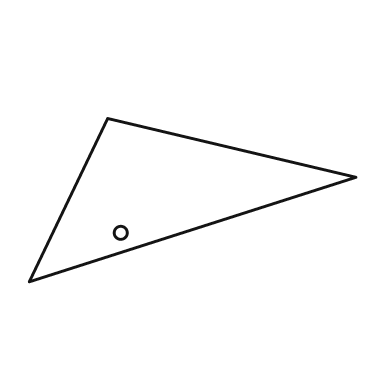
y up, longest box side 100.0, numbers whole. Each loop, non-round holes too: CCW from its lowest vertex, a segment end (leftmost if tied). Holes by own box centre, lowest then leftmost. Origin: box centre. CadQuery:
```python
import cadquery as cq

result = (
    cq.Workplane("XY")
    .moveTo(-50.0, -25.0)
    .lineTo(50.0, 7.0)
    .lineTo(-26.0, 25.0)
    .close()
    .moveTo(-22.0, -10.0)
    .circle(2.0)
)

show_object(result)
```